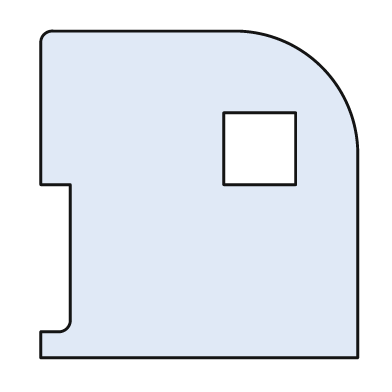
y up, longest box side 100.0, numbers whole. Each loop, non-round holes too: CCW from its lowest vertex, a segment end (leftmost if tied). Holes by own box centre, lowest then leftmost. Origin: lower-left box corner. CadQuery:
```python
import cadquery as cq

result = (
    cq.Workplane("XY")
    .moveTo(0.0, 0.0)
    .lineTo(97.0, 0.0)
    .lineTo(97.0, 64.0)
    .threePointArc((86.0, 89.0), (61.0, 100.0))
    .lineTo(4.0, 100.0)
    .threePointArc((1.0, 99.0), (0.0, 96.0))
    .lineTo(0.0, 53.0)
    .lineTo(9.0, 53.0)
    .lineTo(9.0, 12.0)
    .threePointArc((8.0, 9.0), (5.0, 8.0))
    .lineTo(0.0, 8.0)
    .close()
    .moveTo(56.0, 53.0)
    .lineTo(78.0, 53.0)
    .lineTo(78.0, 75.0)
    .lineTo(56.0, 75.0)
    .close()
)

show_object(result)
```